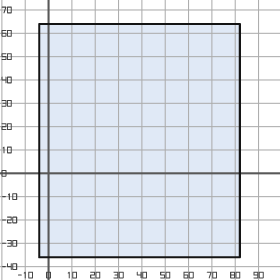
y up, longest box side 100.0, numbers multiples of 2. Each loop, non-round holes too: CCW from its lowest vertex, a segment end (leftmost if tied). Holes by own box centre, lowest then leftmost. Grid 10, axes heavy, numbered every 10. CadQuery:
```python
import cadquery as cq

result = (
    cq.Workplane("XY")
    .moveTo(-4.0, -36.0)
    .lineTo(82.0, -36.0)
    .lineTo(82.0, 64.0)
    .lineTo(-4.0, 64.0)
    .close()
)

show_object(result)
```